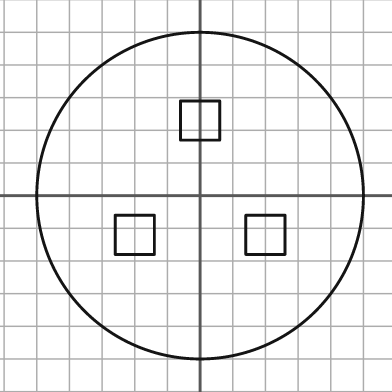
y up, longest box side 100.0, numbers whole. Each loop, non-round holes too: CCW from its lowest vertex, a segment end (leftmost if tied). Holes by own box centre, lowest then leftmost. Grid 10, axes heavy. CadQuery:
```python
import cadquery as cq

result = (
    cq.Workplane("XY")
    .moveTo(0.0, 0.0)
    .circle(50.0)
    .moveTo(-26.0, -18.0)
    .lineTo(-14.0, -18.0)
    .lineTo(-14.0, -6.0)
    .lineTo(-26.0, -6.0)
    .close()
    .moveTo(14.0, -18.0)
    .lineTo(26.0, -18.0)
    .lineTo(26.0, -6.0)
    .lineTo(14.0, -6.0)
    .close()
    .moveTo(-6.0, 17.0)
    .lineTo(6.0, 17.0)
    .lineTo(6.0, 29.0)
    .lineTo(-6.0, 29.0)
    .close()
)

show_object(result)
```